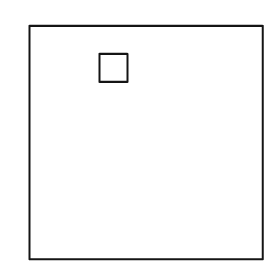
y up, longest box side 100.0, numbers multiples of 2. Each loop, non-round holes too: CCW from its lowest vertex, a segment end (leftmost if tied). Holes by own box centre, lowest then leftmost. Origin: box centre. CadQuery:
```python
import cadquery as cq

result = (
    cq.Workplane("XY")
    .moveTo(-50.0, -50.0)
    .lineTo(50.0, -50.0)
    .lineTo(50.0, 50.0)
    .lineTo(-50.0, 50.0)
    .close()
    .moveTo(-20.0, 26.0)
    .lineTo(-8.0, 26.0)
    .lineTo(-8.0, 38.0)
    .lineTo(-20.0, 38.0)
    .close()
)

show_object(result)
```